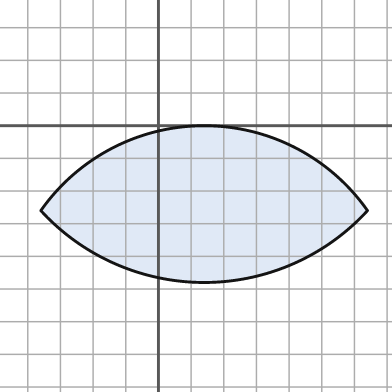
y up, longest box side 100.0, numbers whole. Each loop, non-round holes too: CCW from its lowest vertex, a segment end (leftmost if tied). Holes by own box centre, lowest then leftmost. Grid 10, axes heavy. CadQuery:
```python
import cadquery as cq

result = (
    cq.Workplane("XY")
    .moveTo(-36.0, -26.0)
    .threePointArc((14.0, -48.0), (64.0, -26.0))
    .threePointArc((14.0, 0.0), (-36.0, -26.0))
    .close()
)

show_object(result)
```